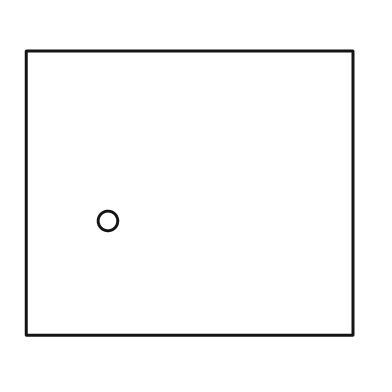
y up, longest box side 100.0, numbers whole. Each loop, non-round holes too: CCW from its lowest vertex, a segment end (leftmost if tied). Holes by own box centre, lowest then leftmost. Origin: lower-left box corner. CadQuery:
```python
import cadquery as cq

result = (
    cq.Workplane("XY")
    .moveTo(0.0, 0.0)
    .lineTo(100.0, 0.0)
    .lineTo(100.0, 87.0)
    .lineTo(0.0, 87.0)
    .close()
    .moveTo(25.0, 35.0)
    .circle(3.0)
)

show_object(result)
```